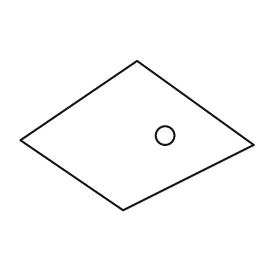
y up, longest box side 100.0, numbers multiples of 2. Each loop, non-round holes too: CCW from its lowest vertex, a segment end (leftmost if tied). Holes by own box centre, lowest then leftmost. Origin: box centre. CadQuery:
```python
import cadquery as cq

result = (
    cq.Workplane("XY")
    .moveTo(-6.0, -32.0)
    .lineTo(50.0, -4.0)
    .lineTo(0.0, 32.0)
    .lineTo(-50.0, -2.0)
    .close()
    .moveTo(12.0, 0.0)
    .circle(4.0)
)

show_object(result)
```